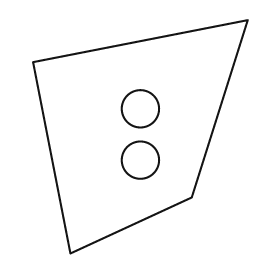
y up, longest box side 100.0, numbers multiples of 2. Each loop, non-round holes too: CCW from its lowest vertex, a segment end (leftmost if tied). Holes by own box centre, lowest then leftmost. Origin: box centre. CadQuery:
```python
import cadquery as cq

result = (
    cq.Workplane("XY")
    .moveTo(-30.0, -50.0)
    .lineTo(22.0, -26.0)
    .lineTo(46.0, 50.0)
    .lineTo(-46.0, 32.0)
    .close()
    .moveTo(0.0, -10.0)
    .circle(8.0)
    .moveTo(0.0, 12.0)
    .circle(8.0)
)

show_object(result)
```